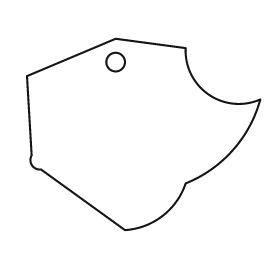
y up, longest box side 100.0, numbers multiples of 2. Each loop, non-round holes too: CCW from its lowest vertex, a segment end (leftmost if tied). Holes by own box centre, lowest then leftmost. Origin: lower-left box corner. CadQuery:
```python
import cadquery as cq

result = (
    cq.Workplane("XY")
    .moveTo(42.0, 0.0)
    .threePointArc((58.0, 6.0), (68.0, 20.0))
    .threePointArc((88.0, 34.0), (100.0, 56.0))
    .threePointArc((78.0, 58.0), (68.0, 78.0))
    .lineTo(38.0, 82.0)
    .lineTo(0.0, 66.0)
    .lineTo(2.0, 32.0)
    .threePointArc((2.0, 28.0), (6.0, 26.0))
    .close()
    .moveTo(38.0, 72.0)
    .circle(4.0)
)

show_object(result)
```